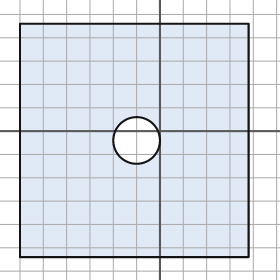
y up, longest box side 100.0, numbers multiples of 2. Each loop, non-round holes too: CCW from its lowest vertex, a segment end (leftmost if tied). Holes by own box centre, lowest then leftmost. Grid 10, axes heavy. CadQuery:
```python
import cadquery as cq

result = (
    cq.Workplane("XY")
    .moveTo(-60.0, -54.0)
    .lineTo(38.0, -54.0)
    .lineTo(38.0, 46.0)
    .lineTo(-60.0, 46.0)
    .close()
    .moveTo(-10.0, -4.0)
    .circle(10.0)
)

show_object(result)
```